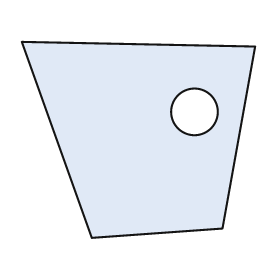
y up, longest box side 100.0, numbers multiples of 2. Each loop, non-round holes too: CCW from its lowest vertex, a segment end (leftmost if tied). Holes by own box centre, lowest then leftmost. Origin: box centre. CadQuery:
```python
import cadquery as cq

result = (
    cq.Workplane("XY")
    .moveTo(-20.0, -42.0)
    .lineTo(36.0, -38.0)
    .lineTo(50.0, 40.0)
    .lineTo(-50.0, 42.0)
    .close()
    .moveTo(24.0, 12.0)
    .circle(10.0)
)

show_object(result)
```